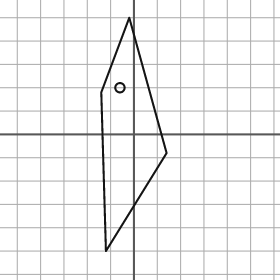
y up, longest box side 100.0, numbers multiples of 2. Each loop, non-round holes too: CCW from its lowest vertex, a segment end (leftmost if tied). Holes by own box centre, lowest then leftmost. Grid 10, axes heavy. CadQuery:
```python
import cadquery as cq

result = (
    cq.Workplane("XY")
    .moveTo(-12.0, -50.0)
    .lineTo(14.0, -8.0)
    .lineTo(-2.0, 50.0)
    .lineTo(-14.0, 18.0)
    .close()
    .moveTo(-6.0, 20.0)
    .circle(2.0)
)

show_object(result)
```